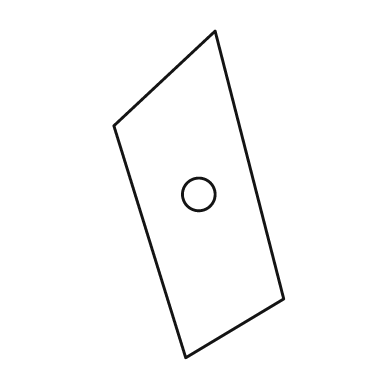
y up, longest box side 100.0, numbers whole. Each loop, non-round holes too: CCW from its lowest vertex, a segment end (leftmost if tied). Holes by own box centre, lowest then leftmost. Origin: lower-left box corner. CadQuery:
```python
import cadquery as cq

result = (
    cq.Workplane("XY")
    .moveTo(22.0, 0.0)
    .lineTo(52.0, 18.0)
    .lineTo(31.0, 100.0)
    .lineTo(0.0, 71.0)
    .close()
    .moveTo(26.0, 50.0)
    .circle(5.0)
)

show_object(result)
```